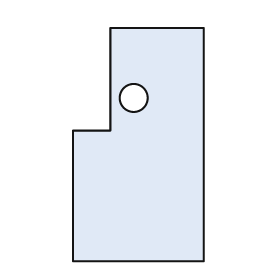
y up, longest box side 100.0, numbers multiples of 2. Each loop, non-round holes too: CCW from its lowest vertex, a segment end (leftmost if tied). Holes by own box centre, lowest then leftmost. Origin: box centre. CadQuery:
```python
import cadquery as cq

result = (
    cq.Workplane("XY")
    .moveTo(-28.0, -50.0)
    .lineTo(28.0, -50.0)
    .lineTo(28.0, 50.0)
    .lineTo(-12.0, 50.0)
    .lineTo(-12.0, 6.0)
    .lineTo(-28.0, 6.0)
    .close()
    .moveTo(-2.0, 20.0)
    .circle(6.0)
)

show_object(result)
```